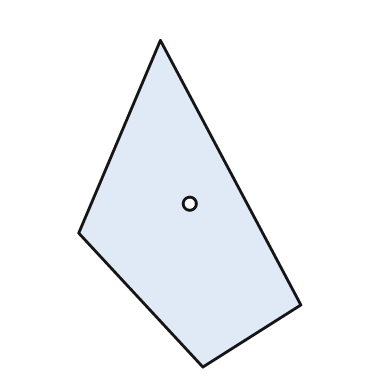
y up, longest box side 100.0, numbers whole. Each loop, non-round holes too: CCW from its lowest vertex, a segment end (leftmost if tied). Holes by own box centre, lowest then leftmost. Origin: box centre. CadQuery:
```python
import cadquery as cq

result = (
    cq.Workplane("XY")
    .moveTo(4.0, -50.0)
    .lineTo(34.0, -31.0)
    .lineTo(-9.0, 50.0)
    .lineTo(-34.0, -9.0)
    .close()
    .moveTo(0.0, 0.0)
    .circle(2.0)
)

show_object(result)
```